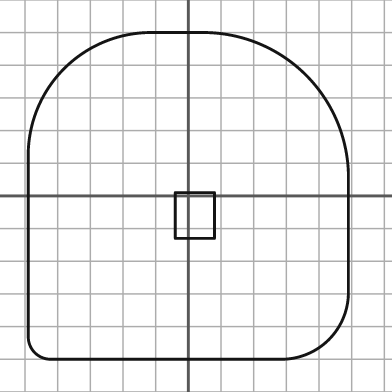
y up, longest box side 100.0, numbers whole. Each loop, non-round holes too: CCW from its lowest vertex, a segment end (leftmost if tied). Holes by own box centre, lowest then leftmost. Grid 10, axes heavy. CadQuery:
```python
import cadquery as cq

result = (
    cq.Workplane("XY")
    .moveTo(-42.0, -50.0)
    .lineTo(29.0, -50.0)
    .threePointArc((43.0, -44.0), (49.0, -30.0))
    .lineTo(49.0, 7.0)
    .threePointArc((36.0, 37.0), (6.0, 50.0))
    .lineTo(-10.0, 50.0)
    .threePointArc((-38.0, 39.0), (-49.0, 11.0))
    .lineTo(-49.0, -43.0)
    .threePointArc((-47.0, -48.0), (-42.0, -50.0))
    .close()
    .moveTo(-4.0, -13.0)
    .lineTo(8.0, -13.0)
    .lineTo(8.0, 1.0)
    .lineTo(-4.0, 1.0)
    .close()
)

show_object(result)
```